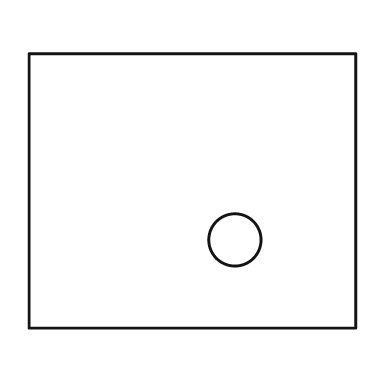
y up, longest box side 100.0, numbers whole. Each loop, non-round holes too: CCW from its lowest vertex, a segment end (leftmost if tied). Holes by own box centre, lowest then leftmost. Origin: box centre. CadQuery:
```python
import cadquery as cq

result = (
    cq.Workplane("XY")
    .moveTo(-50.0, -42.0)
    .lineTo(50.0, -42.0)
    .lineTo(50.0, 42.0)
    .lineTo(-50.0, 42.0)
    .close()
    .moveTo(13.0, -15.0)
    .circle(8.0)
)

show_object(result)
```